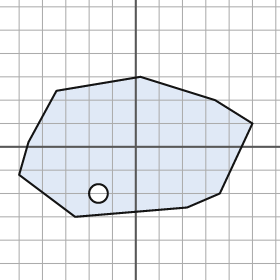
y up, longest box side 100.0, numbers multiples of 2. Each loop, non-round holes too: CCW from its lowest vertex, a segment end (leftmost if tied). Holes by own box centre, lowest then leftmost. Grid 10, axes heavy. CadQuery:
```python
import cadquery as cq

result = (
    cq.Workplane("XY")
    .moveTo(-26.0, -30.0)
    .lineTo(22.0, -26.0)
    .lineTo(36.0, -20.0)
    .lineTo(50.0, 10.0)
    .lineTo(34.0, 20.0)
    .lineTo(2.0, 30.0)
    .lineTo(-34.0, 24.0)
    .lineTo(-46.0, 2.0)
    .lineTo(-50.0, -12.0)
    .close()
    .moveTo(-16.0, -20.0)
    .circle(4.0)
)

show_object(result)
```